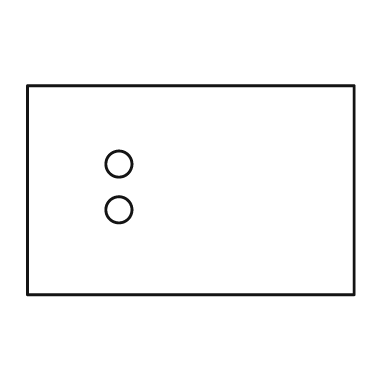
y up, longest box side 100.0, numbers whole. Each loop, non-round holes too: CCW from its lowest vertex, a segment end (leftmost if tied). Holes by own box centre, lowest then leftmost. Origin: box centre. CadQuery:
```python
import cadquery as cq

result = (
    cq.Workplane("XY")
    .moveTo(-50.0, -32.0)
    .lineTo(50.0, -32.0)
    .lineTo(50.0, 32.0)
    .lineTo(-50.0, 32.0)
    .close()
    .moveTo(-22.0, -6.0)
    .circle(4.0)
    .moveTo(-22.0, 8.0)
    .circle(4.0)
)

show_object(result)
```